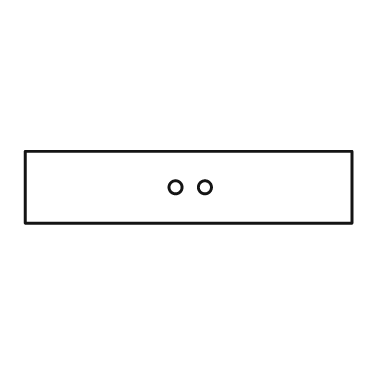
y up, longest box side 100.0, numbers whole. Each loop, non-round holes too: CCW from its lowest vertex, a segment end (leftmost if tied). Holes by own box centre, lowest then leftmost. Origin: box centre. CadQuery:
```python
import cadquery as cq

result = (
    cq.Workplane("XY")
    .moveTo(-50.0, -11.0)
    .lineTo(50.0, -11.0)
    .lineTo(50.0, 11.0)
    .lineTo(-50.0, 11.0)
    .close()
    .moveTo(-4.0, 0.0)
    .circle(2.0)
    .moveTo(5.0, 0.0)
    .circle(2.0)
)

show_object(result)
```